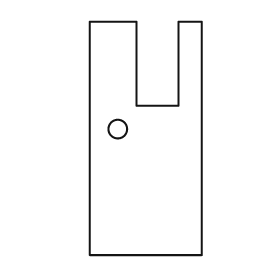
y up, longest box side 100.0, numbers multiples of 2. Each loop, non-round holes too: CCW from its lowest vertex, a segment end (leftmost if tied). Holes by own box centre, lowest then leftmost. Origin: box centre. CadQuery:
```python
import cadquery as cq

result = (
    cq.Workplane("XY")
    .moveTo(-24.0, -50.0)
    .lineTo(24.0, -50.0)
    .lineTo(24.0, 50.0)
    .lineTo(14.0, 50.0)
    .lineTo(14.0, 14.0)
    .lineTo(-4.0, 14.0)
    .lineTo(-4.0, 50.0)
    .lineTo(-24.0, 50.0)
    .close()
    .moveTo(-12.0, 4.0)
    .circle(4.0)
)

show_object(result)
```